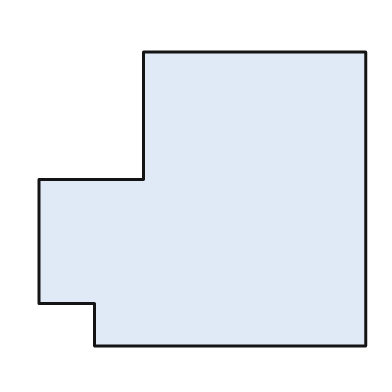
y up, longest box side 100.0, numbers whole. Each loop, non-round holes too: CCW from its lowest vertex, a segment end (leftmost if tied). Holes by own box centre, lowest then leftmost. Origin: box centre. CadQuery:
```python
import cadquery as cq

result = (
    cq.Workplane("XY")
    .moveTo(-33.0, -45.0)
    .lineTo(50.0, -45.0)
    .lineTo(50.0, 45.0)
    .lineTo(-18.0, 45.0)
    .lineTo(-18.0, 6.0)
    .lineTo(-50.0, 6.0)
    .lineTo(-50.0, -32.0)
    .lineTo(-33.0, -32.0)
    .close()
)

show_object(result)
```